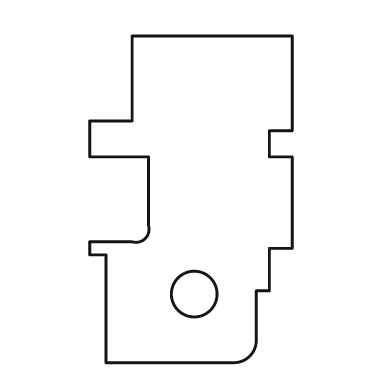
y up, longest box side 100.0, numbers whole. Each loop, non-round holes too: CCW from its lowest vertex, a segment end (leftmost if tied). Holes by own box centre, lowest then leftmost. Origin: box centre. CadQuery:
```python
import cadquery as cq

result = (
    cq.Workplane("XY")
    .moveTo(-26.0, -50.0)
    .lineTo(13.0, -50.0)
    .threePointArc((18.0, -48.0), (20.0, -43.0))
    .lineTo(20.0, -28.0)
    .lineTo(24.0, -28.0)
    .lineTo(24.0, -15.0)
    .lineTo(31.0, -15.0)
    .lineTo(31.0, 13.0)
    .lineTo(24.0, 13.0)
    .lineTo(24.0, 21.0)
    .lineTo(31.0, 21.0)
    .lineTo(31.0, 50.0)
    .lineTo(-18.0, 50.0)
    .lineTo(-18.0, 24.0)
    .lineTo(-31.0, 24.0)
    .lineTo(-31.0, 13.0)
    .lineTo(-13.0, 13.0)
    .lineTo(-13.0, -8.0)
    .threePointArc((-14.0, -12.0), (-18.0, -13.0))
    .lineTo(-31.0, -13.0)
    .lineTo(-31.0, -17.0)
    .lineTo(-26.0, -17.0)
    .close()
    .moveTo(1.0, -29.0)
    .circle(7.0)
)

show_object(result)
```